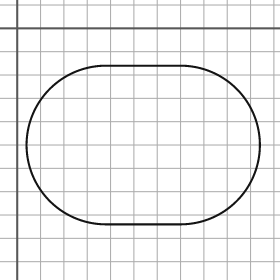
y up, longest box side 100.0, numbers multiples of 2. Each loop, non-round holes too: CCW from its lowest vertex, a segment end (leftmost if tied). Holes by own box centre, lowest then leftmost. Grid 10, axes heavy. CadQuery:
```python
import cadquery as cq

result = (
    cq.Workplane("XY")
    .moveTo(38.0, -84.0)
    .lineTo(70.0, -84.0)
    .threePointArc((104.0, -50.0), (70.0, -16.0))
    .lineTo(38.0, -16.0)
    .threePointArc((4.0, -50.0), (38.0, -84.0))
    .close()
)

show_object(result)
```